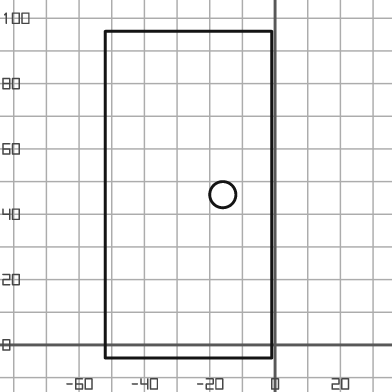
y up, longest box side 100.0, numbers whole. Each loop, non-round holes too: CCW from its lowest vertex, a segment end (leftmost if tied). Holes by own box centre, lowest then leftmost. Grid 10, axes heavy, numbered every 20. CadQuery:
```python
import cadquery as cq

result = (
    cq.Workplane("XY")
    .moveTo(-52.0, -4.0)
    .lineTo(-1.0, -4.0)
    .lineTo(-1.0, 96.0)
    .lineTo(-52.0, 96.0)
    .close()
    .moveTo(-16.0, 46.0)
    .circle(4.0)
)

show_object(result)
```